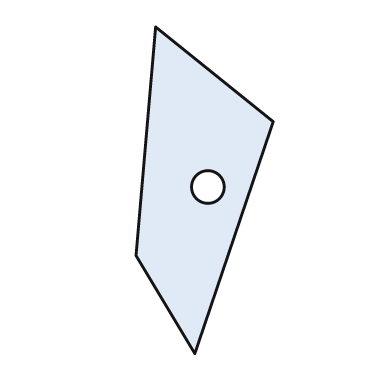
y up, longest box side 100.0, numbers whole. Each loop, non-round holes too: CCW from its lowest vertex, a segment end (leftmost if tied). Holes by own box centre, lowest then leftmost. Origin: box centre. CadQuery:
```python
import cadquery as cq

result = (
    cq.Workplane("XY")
    .moveTo(-3.0, -50.0)
    .lineTo(21.0, 21.0)
    .lineTo(-15.0, 50.0)
    .lineTo(-21.0, -20.0)
    .close()
    .moveTo(1.0, 1.0)
    .circle(5.0)
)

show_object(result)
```